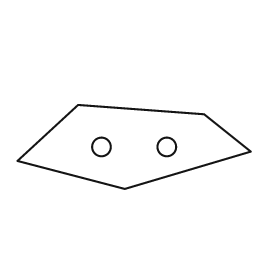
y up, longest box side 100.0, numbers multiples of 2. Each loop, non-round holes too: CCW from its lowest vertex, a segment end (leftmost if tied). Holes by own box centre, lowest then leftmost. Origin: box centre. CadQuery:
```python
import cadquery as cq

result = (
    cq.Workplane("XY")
    .moveTo(-4.0, -18.0)
    .lineTo(50.0, -2.0)
    .lineTo(30.0, 14.0)
    .lineTo(-24.0, 18.0)
    .lineTo(-50.0, -6.0)
    .close()
    .moveTo(-14.0, 0.0)
    .circle(4.0)
    .moveTo(14.0, 0.0)
    .circle(4.0)
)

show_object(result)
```